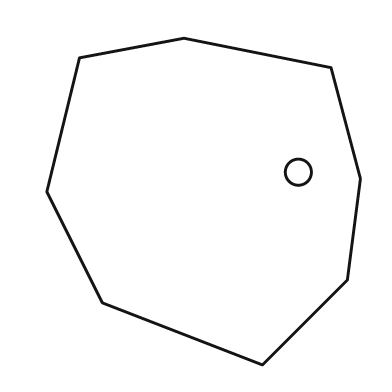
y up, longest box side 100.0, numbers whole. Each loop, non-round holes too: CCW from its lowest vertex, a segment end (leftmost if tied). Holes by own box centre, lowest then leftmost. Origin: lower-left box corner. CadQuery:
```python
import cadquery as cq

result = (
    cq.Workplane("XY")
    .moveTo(66.0, 0.0)
    .lineTo(92.0, 26.0)
    .lineTo(96.0, 57.0)
    .lineTo(87.0, 91.0)
    .lineTo(42.0, 100.0)
    .lineTo(10.0, 94.0)
    .lineTo(0.0, 53.0)
    .lineTo(17.0, 19.0)
    .close()
    .moveTo(77.0, 59.0)
    .circle(4.0)
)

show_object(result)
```